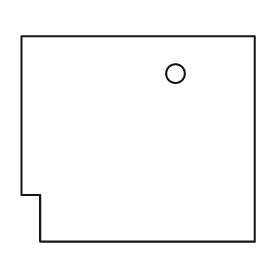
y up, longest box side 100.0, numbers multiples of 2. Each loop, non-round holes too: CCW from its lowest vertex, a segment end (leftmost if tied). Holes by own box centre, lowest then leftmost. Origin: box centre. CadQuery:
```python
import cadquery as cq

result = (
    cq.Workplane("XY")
    .moveTo(-42.0, -44.0)
    .lineTo(50.0, -44.0)
    .lineTo(50.0, 44.0)
    .lineTo(-50.0, 44.0)
    .lineTo(-50.0, -24.0)
    .lineTo(-42.0, -24.0)
    .close()
    .moveTo(16.0, 28.0)
    .circle(4.0)
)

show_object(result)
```